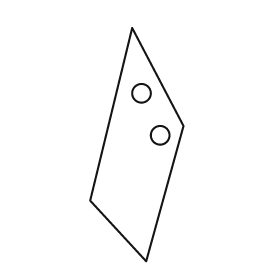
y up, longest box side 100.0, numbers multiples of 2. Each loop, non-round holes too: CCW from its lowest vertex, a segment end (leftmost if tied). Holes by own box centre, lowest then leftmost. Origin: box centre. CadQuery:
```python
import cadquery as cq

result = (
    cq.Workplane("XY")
    .moveTo(4.0, -50.0)
    .lineTo(20.0, 8.0)
    .lineTo(-2.0, 50.0)
    .lineTo(-20.0, -24.0)
    .close()
    .moveTo(10.0, 4.0)
    .circle(4.0)
    .moveTo(2.0, 22.0)
    .circle(4.0)
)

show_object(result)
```